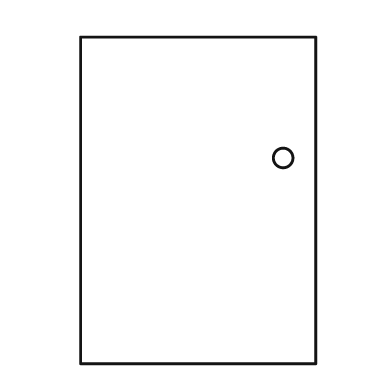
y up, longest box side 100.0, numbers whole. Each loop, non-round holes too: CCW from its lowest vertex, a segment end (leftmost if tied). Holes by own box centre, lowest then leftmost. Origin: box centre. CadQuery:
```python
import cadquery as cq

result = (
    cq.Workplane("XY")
    .moveTo(-36.0, -50.0)
    .lineTo(36.0, -50.0)
    .lineTo(36.0, 50.0)
    .lineTo(-36.0, 50.0)
    .close()
    .moveTo(26.0, 13.0)
    .circle(3.0)
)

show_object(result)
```